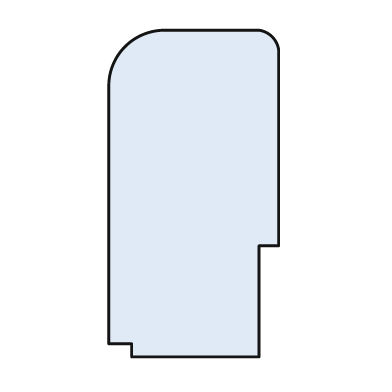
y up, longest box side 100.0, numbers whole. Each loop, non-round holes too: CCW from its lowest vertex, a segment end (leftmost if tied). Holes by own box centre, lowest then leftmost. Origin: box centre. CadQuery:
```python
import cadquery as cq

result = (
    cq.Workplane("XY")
    .moveTo(-19.0, -50.0)
    .lineTo(20.0, -50.0)
    .lineTo(20.0, -16.0)
    .lineTo(26.0, -16.0)
    .lineTo(26.0, 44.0)
    .threePointArc((24.0, 48.0), (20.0, 50.0))
    .lineTo(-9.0, 50.0)
    .threePointArc((-21.0, 45.0), (-26.0, 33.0))
    .lineTo(-26.0, -46.0)
    .lineTo(-19.0, -46.0)
    .close()
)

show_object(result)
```